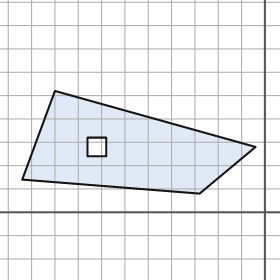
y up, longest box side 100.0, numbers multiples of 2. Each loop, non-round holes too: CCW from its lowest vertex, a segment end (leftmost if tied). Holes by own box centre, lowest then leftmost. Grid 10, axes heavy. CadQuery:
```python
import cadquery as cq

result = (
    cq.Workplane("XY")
    .moveTo(-28.0, 8.0)
    .lineTo(-4.0, 28.0)
    .lineTo(-90.0, 52.0)
    .lineTo(-104.0, 14.0)
    .close()
    .moveTo(-76.0, 24.0)
    .lineTo(-68.0, 24.0)
    .lineTo(-68.0, 32.0)
    .lineTo(-76.0, 32.0)
    .close()
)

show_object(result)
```